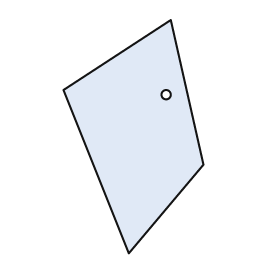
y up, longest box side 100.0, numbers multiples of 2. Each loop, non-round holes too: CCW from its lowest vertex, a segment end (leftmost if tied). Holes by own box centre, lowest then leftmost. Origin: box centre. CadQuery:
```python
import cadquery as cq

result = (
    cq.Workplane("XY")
    .moveTo(-2.0, -50.0)
    .lineTo(30.0, -12.0)
    .lineTo(16.0, 50.0)
    .lineTo(-30.0, 20.0)
    .close()
    .moveTo(14.0, 18.0)
    .circle(2.0)
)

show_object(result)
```